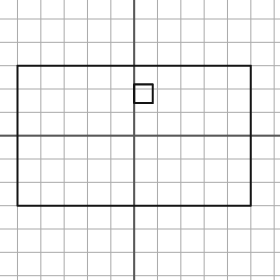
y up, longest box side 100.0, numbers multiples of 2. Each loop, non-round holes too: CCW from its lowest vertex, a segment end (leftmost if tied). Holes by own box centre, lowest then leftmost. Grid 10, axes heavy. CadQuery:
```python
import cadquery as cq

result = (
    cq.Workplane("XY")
    .moveTo(-50.0, -30.0)
    .lineTo(50.0, -30.0)
    .lineTo(50.0, 30.0)
    .lineTo(-50.0, 30.0)
    .close()
    .moveTo(0.0, 14.0)
    .lineTo(8.0, 14.0)
    .lineTo(8.0, 22.0)
    .lineTo(0.0, 22.0)
    .close()
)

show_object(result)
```